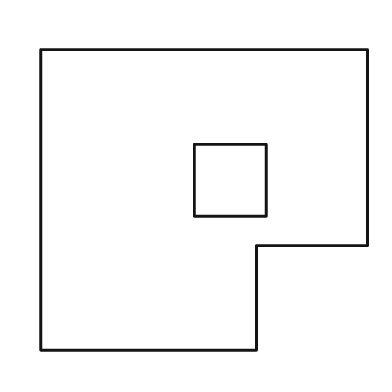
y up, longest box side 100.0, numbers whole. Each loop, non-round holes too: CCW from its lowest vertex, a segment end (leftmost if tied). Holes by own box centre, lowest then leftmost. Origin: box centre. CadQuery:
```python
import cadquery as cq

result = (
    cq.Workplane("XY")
    .moveTo(-50.0, -46.0)
    .lineTo(16.0, -46.0)
    .lineTo(16.0, -14.0)
    .lineTo(50.0, -14.0)
    .lineTo(50.0, 46.0)
    .lineTo(-50.0, 46.0)
    .close()
    .moveTo(-3.0, -5.0)
    .lineTo(19.0, -5.0)
    .lineTo(19.0, 17.0)
    .lineTo(-3.0, 17.0)
    .close()
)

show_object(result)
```